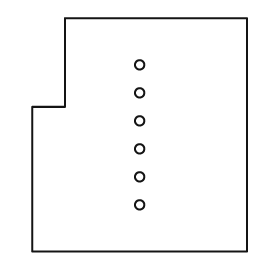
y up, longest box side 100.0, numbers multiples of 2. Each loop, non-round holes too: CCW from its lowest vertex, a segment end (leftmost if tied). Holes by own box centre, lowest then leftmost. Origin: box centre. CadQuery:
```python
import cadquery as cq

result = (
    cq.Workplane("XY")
    .moveTo(-46.0, -50.0)
    .lineTo(46.0, -50.0)
    .lineTo(46.0, 50.0)
    .lineTo(-32.0, 50.0)
    .lineTo(-32.0, 12.0)
    .lineTo(-46.0, 12.0)
    .close()
    .moveTo(0.0, -30.0)
    .circle(2.0)
    .moveTo(0.0, -18.0)
    .circle(2.0)
    .moveTo(0.0, -6.0)
    .circle(2.0)
    .moveTo(0.0, 6.0)
    .circle(2.0)
    .moveTo(0.0, 18.0)
    .circle(2.0)
    .moveTo(0.0, 30.0)
    .circle(2.0)
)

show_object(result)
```